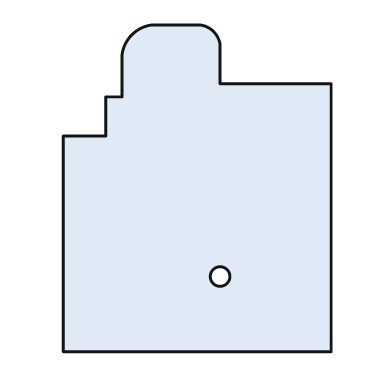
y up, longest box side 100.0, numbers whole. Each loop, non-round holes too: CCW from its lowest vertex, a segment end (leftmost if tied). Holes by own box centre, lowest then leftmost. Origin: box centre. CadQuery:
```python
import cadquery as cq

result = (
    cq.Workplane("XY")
    .moveTo(-41.0, -50.0)
    .lineTo(41.0, -50.0)
    .lineTo(41.0, 32.0)
    .lineTo(7.0, 32.0)
    .lineTo(7.0, 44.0)
    .threePointArc((5.0, 48.0), (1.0, 50.0))
    .lineTo(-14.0, 50.0)
    .threePointArc((-20.0, 47.0), (-23.0, 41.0))
    .lineTo(-23.0, 28.0)
    .lineTo(-28.0, 28.0)
    .lineTo(-28.0, 16.0)
    .lineTo(-41.0, 16.0)
    .close()
    .moveTo(7.0, -27.0)
    .circle(3.0)
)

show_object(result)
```